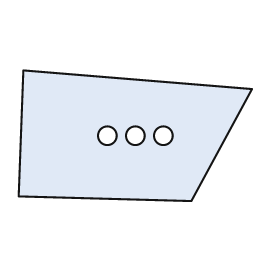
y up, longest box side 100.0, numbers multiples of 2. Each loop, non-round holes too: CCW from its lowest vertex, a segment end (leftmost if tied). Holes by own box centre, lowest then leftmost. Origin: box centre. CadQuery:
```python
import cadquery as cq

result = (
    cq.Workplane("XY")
    .moveTo(24.0, -28.0)
    .lineTo(50.0, 20.0)
    .lineTo(-48.0, 28.0)
    .lineTo(-50.0, -26.0)
    .close()
    .moveTo(-12.0, 0.0)
    .circle(4.0)
    .moveTo(0.0, 0.0)
    .circle(4.0)
    .moveTo(12.0, 0.0)
    .circle(4.0)
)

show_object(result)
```